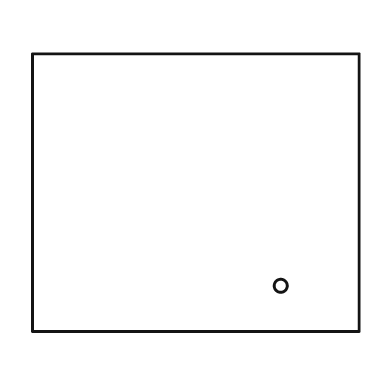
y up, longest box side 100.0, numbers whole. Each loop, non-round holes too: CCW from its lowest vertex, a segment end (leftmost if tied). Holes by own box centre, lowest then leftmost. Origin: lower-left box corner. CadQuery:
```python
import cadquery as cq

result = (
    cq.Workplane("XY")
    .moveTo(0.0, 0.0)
    .lineTo(100.0, 0.0)
    .lineTo(100.0, 85.0)
    .lineTo(0.0, 85.0)
    .close()
    .moveTo(76.0, 14.0)
    .circle(2.0)
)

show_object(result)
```